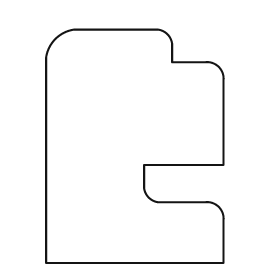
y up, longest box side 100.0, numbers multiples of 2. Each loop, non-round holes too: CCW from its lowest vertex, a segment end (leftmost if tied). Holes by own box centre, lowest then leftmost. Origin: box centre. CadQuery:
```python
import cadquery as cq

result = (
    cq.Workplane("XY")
    .moveTo(-38.0, -50.0)
    .lineTo(38.0, -50.0)
    .lineTo(38.0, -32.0)
    .threePointArc((36.0, -26.0), (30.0, -24.0))
    .lineTo(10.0, -24.0)
    .threePointArc((6.0, -22.0), (4.0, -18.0))
    .lineTo(4.0, -8.0)
    .lineTo(38.0, -8.0)
    .lineTo(38.0, 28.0)
    .threePointArc((36.0, 34.0), (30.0, 36.0))
    .lineTo(16.0, 36.0)
    .lineTo(16.0, 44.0)
    .threePointArc((14.0, 48.0), (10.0, 50.0))
    .lineTo(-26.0, 50.0)
    .threePointArc((-34.0, 46.0), (-38.0, 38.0))
    .close()
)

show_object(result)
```